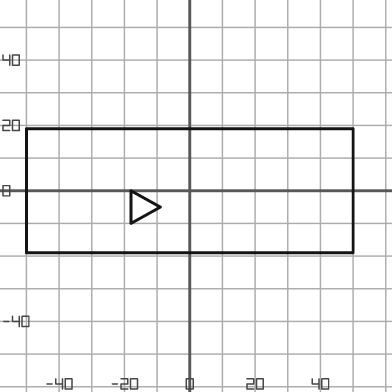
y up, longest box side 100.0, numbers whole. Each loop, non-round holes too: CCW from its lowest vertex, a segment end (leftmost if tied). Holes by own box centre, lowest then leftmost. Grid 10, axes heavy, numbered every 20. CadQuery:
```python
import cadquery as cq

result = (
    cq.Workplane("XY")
    .moveTo(-50.0, -19.0)
    .lineTo(50.0, -19.0)
    .lineTo(50.0, 19.0)
    .lineTo(-50.0, 19.0)
    .close()
    .moveTo(-18.0, -10.0)
    .lineTo(-9.0, -5.0)
    .lineTo(-18.0, 0.0)
    .close()
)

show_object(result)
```